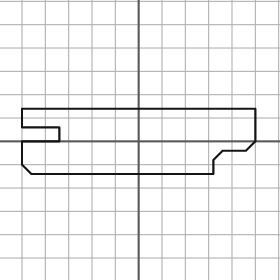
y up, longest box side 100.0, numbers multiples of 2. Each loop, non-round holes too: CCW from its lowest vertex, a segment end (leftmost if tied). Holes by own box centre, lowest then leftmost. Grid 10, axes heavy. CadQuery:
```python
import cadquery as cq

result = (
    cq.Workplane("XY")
    .moveTo(-46.0, -14.0)
    .lineTo(32.0, -14.0)
    .lineTo(32.0, -8.0)
    .lineTo(36.0, -4.0)
    .lineTo(46.0, -4.0)
    .lineTo(50.0, 0.0)
    .lineTo(50.0, 14.0)
    .lineTo(-50.0, 14.0)
    .lineTo(-50.0, 6.0)
    .lineTo(-34.0, 6.0)
    .lineTo(-34.0, 0.0)
    .lineTo(-50.0, 0.0)
    .lineTo(-50.0, -10.0)
    .close()
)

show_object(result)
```